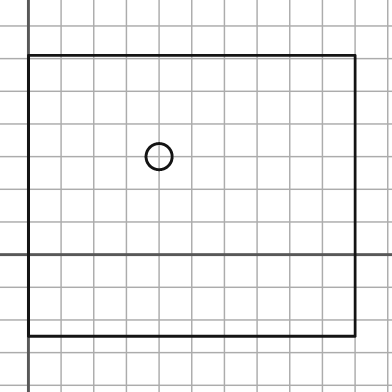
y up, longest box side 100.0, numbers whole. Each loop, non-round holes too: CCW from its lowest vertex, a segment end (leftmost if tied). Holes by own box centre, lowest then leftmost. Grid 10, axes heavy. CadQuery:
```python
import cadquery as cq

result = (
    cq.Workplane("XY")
    .moveTo(0.0, -25.0)
    .lineTo(100.0, -25.0)
    .lineTo(100.0, 61.0)
    .lineTo(0.0, 61.0)
    .close()
    .moveTo(40.0, 30.0)
    .circle(4.0)
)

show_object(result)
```